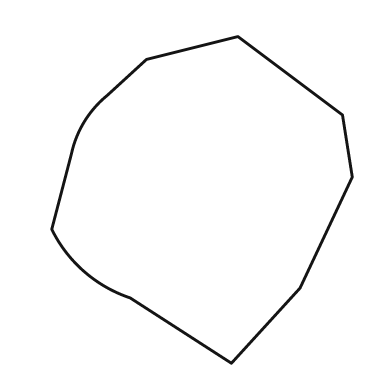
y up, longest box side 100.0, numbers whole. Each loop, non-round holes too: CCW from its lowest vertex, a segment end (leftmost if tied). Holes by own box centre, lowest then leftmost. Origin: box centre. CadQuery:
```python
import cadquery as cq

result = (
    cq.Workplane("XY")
    .moveTo(9.0, -50.0)
    .lineTo(30.0, -27.0)
    .lineTo(46.0, 7.0)
    .lineTo(43.0, 26.0)
    .lineTo(11.0, 50.0)
    .lineTo(-17.0, 43.0)
    .lineTo(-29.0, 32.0)
    .threePointArc((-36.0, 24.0), (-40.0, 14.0))
    .lineTo(-46.0, -9.0)
    .threePointArc((-36.0, -22.0), (-22.0, -30.0))
    .close()
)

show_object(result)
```